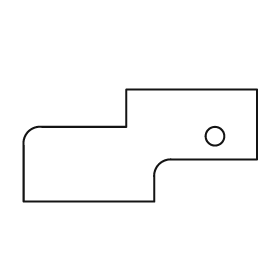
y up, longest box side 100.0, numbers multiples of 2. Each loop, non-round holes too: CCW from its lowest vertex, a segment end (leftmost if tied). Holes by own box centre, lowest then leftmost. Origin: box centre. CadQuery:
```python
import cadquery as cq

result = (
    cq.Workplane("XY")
    .moveTo(-50.0, -24.0)
    .lineTo(6.0, -24.0)
    .lineTo(6.0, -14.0)
    .threePointArc((8.0, -8.0), (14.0, -6.0))
    .lineTo(50.0, -6.0)
    .lineTo(50.0, 24.0)
    .lineTo(-6.0, 24.0)
    .lineTo(-6.0, 8.0)
    .lineTo(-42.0, 8.0)
    .threePointArc((-48.0, 6.0), (-50.0, 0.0))
    .close()
    .moveTo(32.0, 4.0)
    .circle(4.0)
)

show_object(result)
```